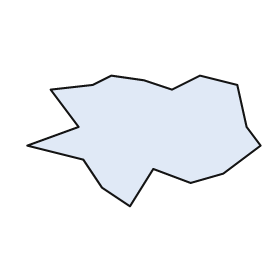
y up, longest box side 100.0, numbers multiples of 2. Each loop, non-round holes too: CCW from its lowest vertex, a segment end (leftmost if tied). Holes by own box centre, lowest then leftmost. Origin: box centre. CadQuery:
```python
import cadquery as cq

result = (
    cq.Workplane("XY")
    .moveTo(-6.0, -28.0)
    .lineTo(4.0, -12.0)
    .lineTo(20.0, -18.0)
    .lineTo(34.0, -14.0)
    .lineTo(50.0, -2.0)
    .lineTo(44.0, 6.0)
    .lineTo(40.0, 24.0)
    .lineTo(24.0, 28.0)
    .lineTo(12.0, 22.0)
    .lineTo(0.0, 26.0)
    .lineTo(-14.0, 28.0)
    .lineTo(-22.0, 24.0)
    .lineTo(-40.0, 22.0)
    .lineTo(-28.0, 6.0)
    .lineTo(-50.0, -2.0)
    .lineTo(-26.0, -8.0)
    .lineTo(-18.0, -20.0)
    .close()
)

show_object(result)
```